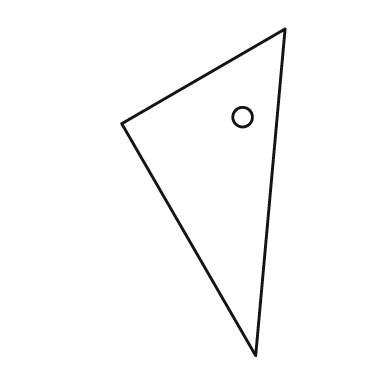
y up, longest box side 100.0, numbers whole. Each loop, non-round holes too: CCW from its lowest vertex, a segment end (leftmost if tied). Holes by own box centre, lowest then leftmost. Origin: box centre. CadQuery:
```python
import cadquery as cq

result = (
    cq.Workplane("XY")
    .moveTo(16.0, -50.0)
    .lineTo(25.0, 50.0)
    .lineTo(-25.0, 21.0)
    .close()
    .moveTo(12.0, 23.0)
    .circle(3.0)
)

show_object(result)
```